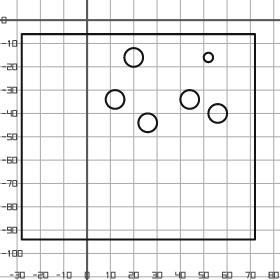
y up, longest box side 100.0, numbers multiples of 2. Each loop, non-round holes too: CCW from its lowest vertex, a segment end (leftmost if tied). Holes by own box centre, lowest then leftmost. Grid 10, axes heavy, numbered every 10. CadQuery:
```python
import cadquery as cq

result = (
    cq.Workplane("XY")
    .moveTo(-28.0, -94.0)
    .lineTo(72.0, -94.0)
    .lineTo(72.0, -6.0)
    .lineTo(-28.0, -6.0)
    .close()
    .moveTo(26.0, -44.0)
    .circle(4.0)
    .moveTo(56.0, -40.0)
    .circle(4.0)
    .moveTo(12.0, -34.0)
    .circle(4.0)
    .moveTo(44.0, -34.0)
    .circle(4.0)
    .moveTo(20.0, -16.0)
    .circle(4.0)
    .moveTo(52.0, -16.0)
    .circle(2.0)
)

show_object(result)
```